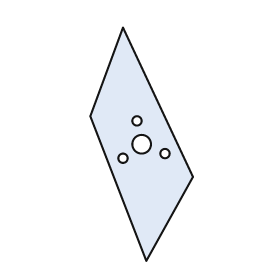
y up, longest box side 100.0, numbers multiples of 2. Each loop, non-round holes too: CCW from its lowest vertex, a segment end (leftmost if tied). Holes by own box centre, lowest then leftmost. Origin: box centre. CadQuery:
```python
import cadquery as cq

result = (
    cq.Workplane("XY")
    .moveTo(2.0, -50.0)
    .lineTo(22.0, -14.0)
    .lineTo(-8.0, 50.0)
    .lineTo(-22.0, 12.0)
    .close()
    .moveTo(-8.0, -6.0)
    .circle(2.0)
    .moveTo(10.0, -4.0)
    .circle(2.0)
    .moveTo(0.0, 0.0)
    .circle(4.0)
    .moveTo(-2.0, 10.0)
    .circle(2.0)
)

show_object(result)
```